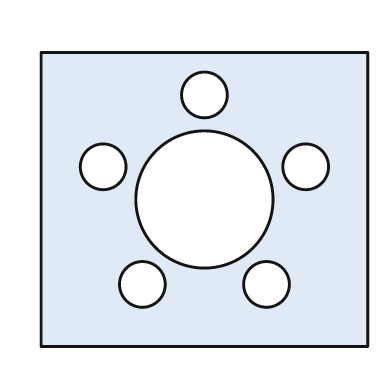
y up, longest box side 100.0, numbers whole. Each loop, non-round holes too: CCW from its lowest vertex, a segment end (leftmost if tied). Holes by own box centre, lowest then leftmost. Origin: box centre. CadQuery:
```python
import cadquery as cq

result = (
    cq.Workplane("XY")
    .moveTo(-50.0, -45.0)
    .lineTo(50.0, -45.0)
    .lineTo(50.0, 45.0)
    .lineTo(-50.0, 45.0)
    .close()
    .moveTo(-19.0, -26.0)
    .circle(7.0)
    .moveTo(19.0, -26.0)
    .circle(7.0)
    .moveTo(0.0, 0.0)
    .circle(21.0)
    .moveTo(-31.0, 10.0)
    .circle(7.0)
    .moveTo(31.0, 10.0)
    .circle(7.0)
    .moveTo(0.0, 32.0)
    .circle(7.0)
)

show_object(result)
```